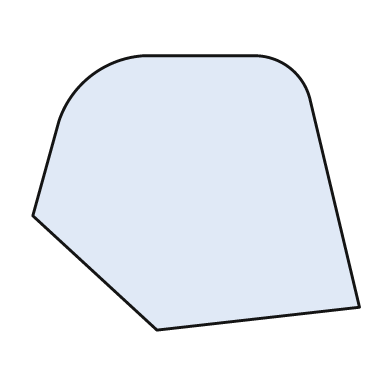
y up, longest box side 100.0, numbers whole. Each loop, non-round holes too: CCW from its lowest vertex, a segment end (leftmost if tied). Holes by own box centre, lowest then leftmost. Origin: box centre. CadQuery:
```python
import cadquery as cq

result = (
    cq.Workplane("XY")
    .moveTo(-12.0, -42.0)
    .lineTo(50.0, -35.0)
    .lineTo(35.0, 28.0)
    .threePointArc((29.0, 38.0), (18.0, 42.0))
    .lineTo(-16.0, 42.0)
    .threePointArc((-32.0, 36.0), (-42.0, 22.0))
    .lineTo(-50.0, -7.0)
    .close()
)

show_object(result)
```